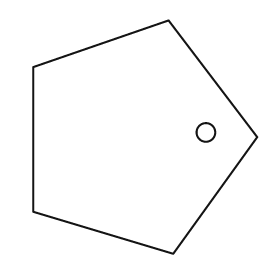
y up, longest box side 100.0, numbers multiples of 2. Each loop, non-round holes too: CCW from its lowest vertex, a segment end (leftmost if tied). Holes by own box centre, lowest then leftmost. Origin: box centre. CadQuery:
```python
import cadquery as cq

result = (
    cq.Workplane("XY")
    .moveTo(12.0, -50.0)
    .lineTo(48.0, 0.0)
    .lineTo(10.0, 50.0)
    .lineTo(-48.0, 30.0)
    .lineTo(-48.0, -32.0)
    .close()
    .moveTo(26.0, 2.0)
    .circle(4.0)
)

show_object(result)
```